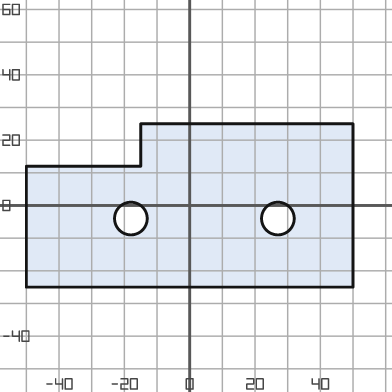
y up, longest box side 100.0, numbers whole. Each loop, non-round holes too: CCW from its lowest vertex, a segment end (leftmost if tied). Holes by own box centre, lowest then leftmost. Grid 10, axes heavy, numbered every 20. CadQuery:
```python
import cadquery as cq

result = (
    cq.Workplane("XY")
    .moveTo(-50.0, -25.0)
    .lineTo(50.0, -25.0)
    .lineTo(50.0, 25.0)
    .lineTo(-15.0, 25.0)
    .lineTo(-15.0, 12.0)
    .lineTo(-50.0, 12.0)
    .close()
    .moveTo(-18.0, -4.0)
    .circle(5.0)
    .moveTo(27.0, -4.0)
    .circle(5.0)
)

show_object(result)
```